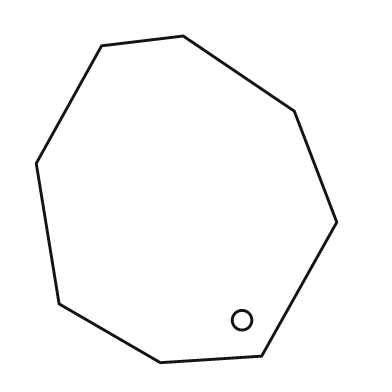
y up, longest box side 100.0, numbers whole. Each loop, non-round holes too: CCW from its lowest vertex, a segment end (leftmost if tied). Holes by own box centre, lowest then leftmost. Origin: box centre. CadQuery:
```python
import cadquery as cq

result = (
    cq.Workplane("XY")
    .moveTo(-8.0, -50.0)
    .lineTo(23.0, -48.0)
    .lineTo(46.0, -7.0)
    .lineTo(33.0, 27.0)
    .lineTo(-1.0, 50.0)
    .lineTo(-26.0, 47.0)
    .lineTo(-46.0, 11.0)
    .lineTo(-39.0, -32.0)
    .close()
    .moveTo(17.0, -37.0)
    .circle(3.0)
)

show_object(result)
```